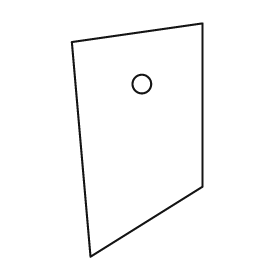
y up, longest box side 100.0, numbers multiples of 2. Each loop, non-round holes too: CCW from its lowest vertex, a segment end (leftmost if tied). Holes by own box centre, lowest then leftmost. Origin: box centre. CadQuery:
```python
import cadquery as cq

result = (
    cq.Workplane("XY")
    .moveTo(-20.0, -50.0)
    .lineTo(28.0, -20.0)
    .lineTo(28.0, 50.0)
    .lineTo(-28.0, 42.0)
    .close()
    .moveTo(2.0, 24.0)
    .circle(4.0)
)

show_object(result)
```